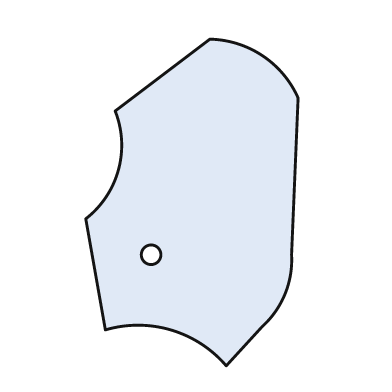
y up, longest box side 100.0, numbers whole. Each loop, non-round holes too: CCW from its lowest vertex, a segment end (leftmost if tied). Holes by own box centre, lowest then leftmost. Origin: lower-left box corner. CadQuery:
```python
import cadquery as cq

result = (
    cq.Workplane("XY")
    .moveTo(43.0, 0.0)
    .lineTo(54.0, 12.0)
    .threePointArc((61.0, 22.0), (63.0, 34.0))
    .lineTo(65.0, 82.0)
    .threePointArc((54.0, 95.0), (38.0, 100.0))
    .lineTo(9.0, 78.0)
    .threePointArc((10.0, 60.0), (0.0, 45.0))
    .lineTo(6.0, 11.0)
    .threePointArc((26.0, 11.0), (43.0, 0.0))
    .close()
    .moveTo(20.0, 34.0)
    .circle(3.0)
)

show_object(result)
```